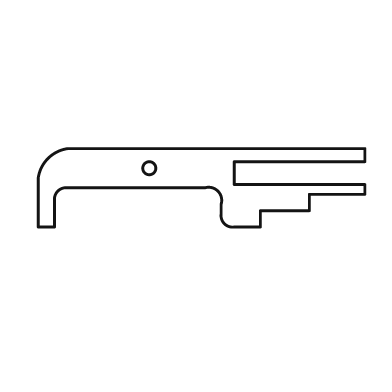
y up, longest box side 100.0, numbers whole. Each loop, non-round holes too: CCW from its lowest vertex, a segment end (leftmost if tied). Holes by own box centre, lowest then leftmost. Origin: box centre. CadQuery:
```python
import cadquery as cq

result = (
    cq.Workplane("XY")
    .moveTo(-50.0, -12.0)
    .lineTo(-45.0, -12.0)
    .lineTo(-45.0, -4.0)
    .threePointArc((-44.0, -1.0), (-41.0, 0.0))
    .lineTo(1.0, 0.0)
    .threePointArc((5.0, -1.0), (6.0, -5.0))
    .lineTo(6.0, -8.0)
    .threePointArc((7.0, -11.0), (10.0, -12.0))
    .lineTo(18.0, -12.0)
    .lineTo(18.0, -7.0)
    .lineTo(33.0, -7.0)
    .lineTo(33.0, -2.0)
    .lineTo(50.0, -2.0)
    .lineTo(50.0, 1.0)
    .lineTo(10.0, 1.0)
    .lineTo(10.0, 8.0)
    .lineTo(50.0, 8.0)
    .lineTo(50.0, 12.0)
    .lineTo(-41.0, 12.0)
    .threePointArc((-47.0, 9.0), (-50.0, 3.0))
    .close()
    .moveTo(-16.0, 6.0)
    .circle(2.0)
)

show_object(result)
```